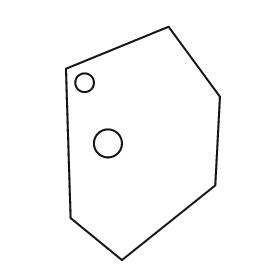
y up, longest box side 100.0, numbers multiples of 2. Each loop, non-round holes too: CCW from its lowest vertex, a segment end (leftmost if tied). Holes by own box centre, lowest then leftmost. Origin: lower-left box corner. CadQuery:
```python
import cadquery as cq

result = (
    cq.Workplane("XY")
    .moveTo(24.0, 0.0)
    .lineTo(64.0, 32.0)
    .lineTo(66.0, 70.0)
    .lineTo(44.0, 100.0)
    .lineTo(0.0, 82.0)
    .lineTo(2.0, 18.0)
    .close()
    .moveTo(18.0, 50.0)
    .circle(6.0)
    .moveTo(8.0, 76.0)
    .circle(4.0)
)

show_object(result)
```